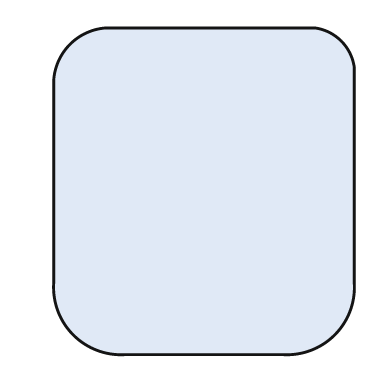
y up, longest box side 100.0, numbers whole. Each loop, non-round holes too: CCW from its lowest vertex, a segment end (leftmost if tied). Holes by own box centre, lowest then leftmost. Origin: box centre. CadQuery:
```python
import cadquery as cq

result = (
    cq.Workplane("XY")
    .moveTo(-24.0, -50.0)
    .lineTo(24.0, -50.0)
    .threePointArc((40.0, -44.0), (46.0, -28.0))
    .lineTo(46.0, 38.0)
    .threePointArc((42.0, 46.0), (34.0, 50.0))
    .lineTo(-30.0, 50.0)
    .threePointArc((-41.0, 45.0), (-46.0, 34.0))
    .lineTo(-46.0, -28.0)
    .threePointArc((-40.0, -44.0), (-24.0, -50.0))
    .close()
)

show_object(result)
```